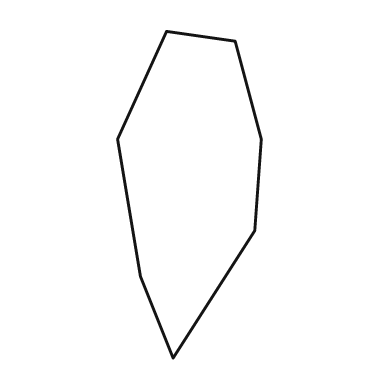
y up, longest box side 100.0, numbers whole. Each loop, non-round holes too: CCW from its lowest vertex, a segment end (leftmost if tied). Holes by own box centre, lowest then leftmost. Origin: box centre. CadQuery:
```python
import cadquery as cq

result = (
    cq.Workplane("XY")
    .moveTo(-5.0, -50.0)
    .lineTo(20.0, -11.0)
    .lineTo(22.0, 17.0)
    .lineTo(14.0, 47.0)
    .lineTo(-7.0, 50.0)
    .lineTo(-22.0, 17.0)
    .lineTo(-15.0, -25.0)
    .close()
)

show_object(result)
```